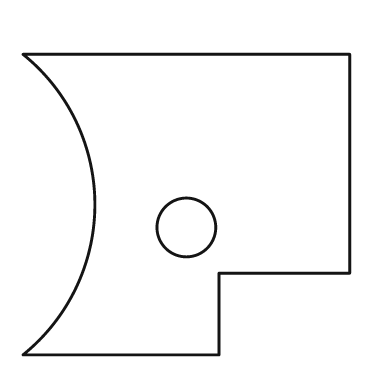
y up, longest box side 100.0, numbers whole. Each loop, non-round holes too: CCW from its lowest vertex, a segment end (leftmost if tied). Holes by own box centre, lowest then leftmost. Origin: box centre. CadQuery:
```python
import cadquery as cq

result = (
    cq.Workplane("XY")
    .moveTo(-50.0, -46.0)
    .lineTo(10.0, -46.0)
    .lineTo(10.0, -21.0)
    .lineTo(50.0, -21.0)
    .lineTo(50.0, 46.0)
    .lineTo(-50.0, 46.0)
    .threePointArc((-28.0, 0.0), (-50.0, -46.0))
    .close()
    .moveTo(0.0, -7.0)
    .circle(9.0)
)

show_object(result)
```